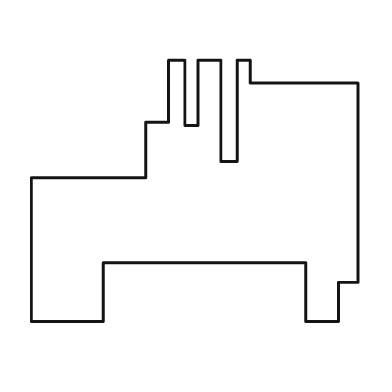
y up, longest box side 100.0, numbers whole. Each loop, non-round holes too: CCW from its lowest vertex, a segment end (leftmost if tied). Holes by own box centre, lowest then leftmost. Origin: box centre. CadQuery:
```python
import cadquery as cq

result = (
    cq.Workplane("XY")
    .moveTo(-50.0, -40.0)
    .lineTo(-28.0, -40.0)
    .lineTo(-28.0, -22.0)
    .lineTo(34.0, -22.0)
    .lineTo(34.0, -40.0)
    .lineTo(44.0, -40.0)
    .lineTo(44.0, -28.0)
    .lineTo(50.0, -28.0)
    .lineTo(50.0, 33.0)
    .lineTo(17.0, 33.0)
    .lineTo(17.0, 40.0)
    .lineTo(13.0, 40.0)
    .lineTo(13.0, 9.0)
    .lineTo(8.0, 9.0)
    .lineTo(8.0, 40.0)
    .lineTo(1.0, 40.0)
    .lineTo(1.0, 20.0)
    .lineTo(-3.0, 20.0)
    .lineTo(-3.0, 40.0)
    .lineTo(-8.0, 40.0)
    .lineTo(-8.0, 21.0)
    .lineTo(-15.0, 21.0)
    .lineTo(-15.0, 4.0)
    .lineTo(-50.0, 4.0)
    .close()
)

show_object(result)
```